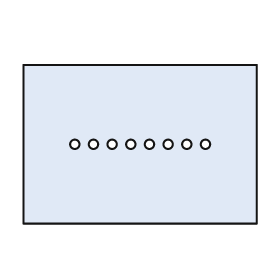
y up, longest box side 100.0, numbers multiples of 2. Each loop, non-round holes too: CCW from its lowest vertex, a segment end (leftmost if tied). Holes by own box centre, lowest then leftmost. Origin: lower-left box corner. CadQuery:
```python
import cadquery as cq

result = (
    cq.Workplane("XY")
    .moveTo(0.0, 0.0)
    .lineTo(100.0, 0.0)
    .lineTo(100.0, 68.0)
    .lineTo(0.0, 68.0)
    .close()
    .moveTo(22.0, 34.0)
    .circle(2.0)
    .moveTo(30.0, 34.0)
    .circle(2.0)
    .moveTo(38.0, 34.0)
    .circle(2.0)
    .moveTo(46.0, 34.0)
    .circle(2.0)
    .moveTo(54.0, 34.0)
    .circle(2.0)
    .moveTo(62.0, 34.0)
    .circle(2.0)
    .moveTo(70.0, 34.0)
    .circle(2.0)
    .moveTo(78.0, 34.0)
    .circle(2.0)
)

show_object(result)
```